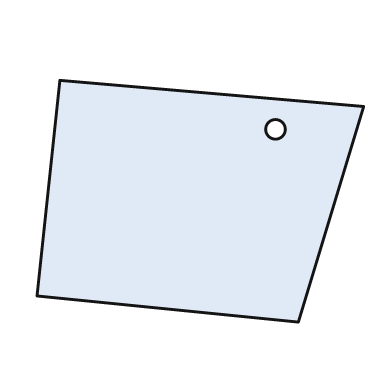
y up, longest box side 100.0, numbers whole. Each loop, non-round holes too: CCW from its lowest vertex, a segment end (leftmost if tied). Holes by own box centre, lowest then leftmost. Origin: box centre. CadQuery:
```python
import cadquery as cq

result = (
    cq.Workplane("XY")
    .moveTo(30.0, -37.0)
    .lineTo(50.0, 29.0)
    .lineTo(-43.0, 37.0)
    .lineTo(-50.0, -29.0)
    .close()
    .moveTo(23.0, 22.0)
    .circle(3.0)
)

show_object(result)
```